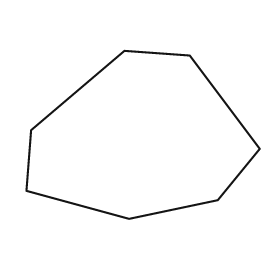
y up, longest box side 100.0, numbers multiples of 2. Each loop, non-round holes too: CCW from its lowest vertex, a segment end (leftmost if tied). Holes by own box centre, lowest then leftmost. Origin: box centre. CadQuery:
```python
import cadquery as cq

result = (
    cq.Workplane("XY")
    .moveTo(-6.0, -36.0)
    .lineTo(32.0, -28.0)
    .lineTo(50.0, -6.0)
    .lineTo(20.0, 34.0)
    .lineTo(-8.0, 36.0)
    .lineTo(-48.0, 2.0)
    .lineTo(-50.0, -24.0)
    .close()
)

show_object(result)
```